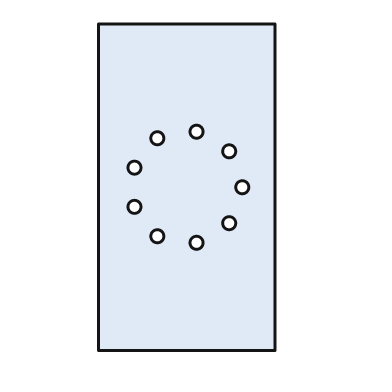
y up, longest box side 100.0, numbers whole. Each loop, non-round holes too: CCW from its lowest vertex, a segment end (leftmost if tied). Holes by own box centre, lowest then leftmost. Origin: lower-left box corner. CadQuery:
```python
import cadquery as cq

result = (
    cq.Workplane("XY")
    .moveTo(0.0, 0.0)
    .lineTo(54.0, 0.0)
    .lineTo(54.0, 100.0)
    .lineTo(0.0, 100.0)
    .close()
    .moveTo(30.0, 33.0)
    .circle(2.0)
    .moveTo(18.0, 35.0)
    .circle(2.0)
    .moveTo(40.0, 39.0)
    .circle(2.0)
    .moveTo(11.0, 44.0)
    .circle(2.0)
    .moveTo(44.0, 50.0)
    .circle(2.0)
    .moveTo(11.0, 56.0)
    .circle(2.0)
    .moveTo(40.0, 61.0)
    .circle(2.0)
    .moveTo(18.0, 65.0)
    .circle(2.0)
    .moveTo(30.0, 67.0)
    .circle(2.0)
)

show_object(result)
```